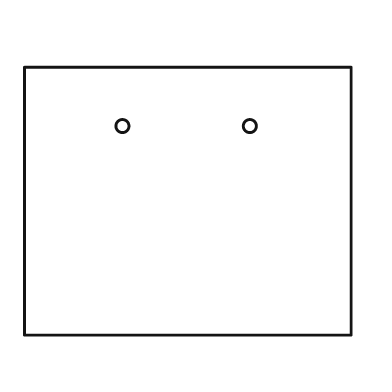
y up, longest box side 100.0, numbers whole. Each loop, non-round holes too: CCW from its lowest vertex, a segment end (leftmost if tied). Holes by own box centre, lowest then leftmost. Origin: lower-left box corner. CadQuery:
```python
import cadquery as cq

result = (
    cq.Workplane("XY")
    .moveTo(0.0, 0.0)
    .lineTo(100.0, 0.0)
    .lineTo(100.0, 82.0)
    .lineTo(0.0, 82.0)
    .close()
    .moveTo(30.0, 64.0)
    .circle(2.0)
    .moveTo(69.0, 64.0)
    .circle(2.0)
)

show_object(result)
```